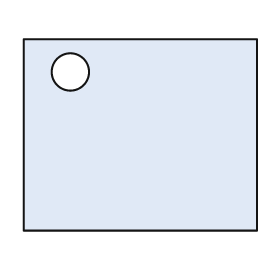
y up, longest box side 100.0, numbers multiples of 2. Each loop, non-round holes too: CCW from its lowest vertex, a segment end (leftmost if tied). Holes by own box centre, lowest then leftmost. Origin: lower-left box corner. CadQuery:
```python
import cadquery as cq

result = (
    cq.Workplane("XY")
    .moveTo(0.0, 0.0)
    .lineTo(100.0, 0.0)
    .lineTo(100.0, 82.0)
    .lineTo(0.0, 82.0)
    .close()
    .moveTo(20.0, 68.0)
    .circle(8.0)
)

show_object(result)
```